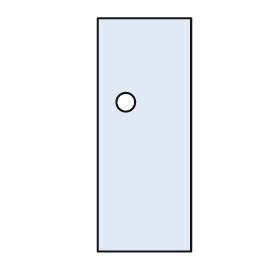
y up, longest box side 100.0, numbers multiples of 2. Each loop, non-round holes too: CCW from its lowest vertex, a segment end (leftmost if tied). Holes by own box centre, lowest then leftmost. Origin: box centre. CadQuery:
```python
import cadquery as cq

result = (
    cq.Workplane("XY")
    .moveTo(-20.0, -50.0)
    .lineTo(20.0, -50.0)
    .lineTo(20.0, 50.0)
    .lineTo(-20.0, 50.0)
    .close()
    .moveTo(-8.0, 14.0)
    .circle(4.0)
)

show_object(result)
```